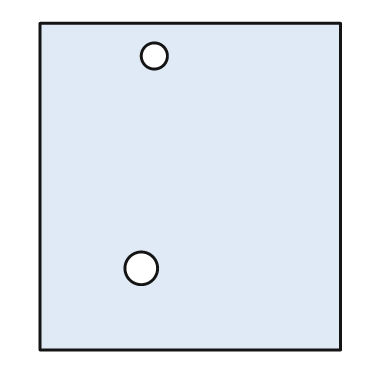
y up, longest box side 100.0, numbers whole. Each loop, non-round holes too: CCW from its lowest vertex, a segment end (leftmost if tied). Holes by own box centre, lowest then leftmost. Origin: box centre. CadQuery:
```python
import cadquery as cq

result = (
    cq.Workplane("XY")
    .moveTo(-46.0, -50.0)
    .lineTo(46.0, -50.0)
    .lineTo(46.0, 50.0)
    .lineTo(-46.0, 50.0)
    .close()
    .moveTo(-15.0, -25.0)
    .circle(5.0)
    .moveTo(-11.0, 40.0)
    .circle(4.0)
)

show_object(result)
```